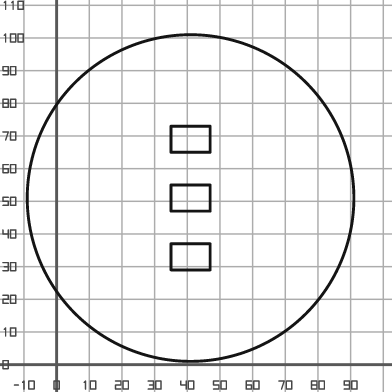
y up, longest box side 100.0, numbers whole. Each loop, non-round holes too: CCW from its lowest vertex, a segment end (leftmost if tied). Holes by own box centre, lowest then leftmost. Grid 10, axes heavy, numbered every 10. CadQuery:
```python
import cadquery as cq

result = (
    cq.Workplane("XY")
    .moveTo(41.0, 51.0)
    .circle(50.0)
    .moveTo(35.0, 29.0)
    .lineTo(47.0, 29.0)
    .lineTo(47.0, 37.0)
    .lineTo(35.0, 37.0)
    .close()
    .moveTo(35.0, 47.0)
    .lineTo(47.0, 47.0)
    .lineTo(47.0, 55.0)
    .lineTo(35.0, 55.0)
    .close()
    .moveTo(35.0, 65.0)
    .lineTo(47.0, 65.0)
    .lineTo(47.0, 73.0)
    .lineTo(35.0, 73.0)
    .close()
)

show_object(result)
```